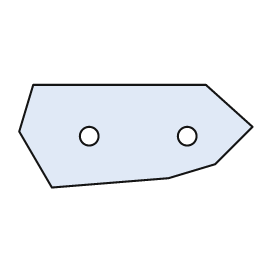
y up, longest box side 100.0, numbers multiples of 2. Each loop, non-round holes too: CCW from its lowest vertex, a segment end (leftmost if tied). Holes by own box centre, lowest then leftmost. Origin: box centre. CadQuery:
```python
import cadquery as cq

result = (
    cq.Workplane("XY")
    .moveTo(-36.0, -22.0)
    .lineTo(14.0, -18.0)
    .lineTo(34.0, -12.0)
    .lineTo(50.0, 4.0)
    .lineTo(30.0, 22.0)
    .lineTo(-44.0, 22.0)
    .lineTo(-50.0, 2.0)
    .close()
    .moveTo(-20.0, 0.0)
    .circle(4.0)
    .moveTo(22.0, 0.0)
    .circle(4.0)
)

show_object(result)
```